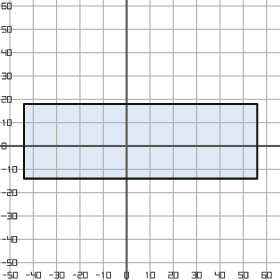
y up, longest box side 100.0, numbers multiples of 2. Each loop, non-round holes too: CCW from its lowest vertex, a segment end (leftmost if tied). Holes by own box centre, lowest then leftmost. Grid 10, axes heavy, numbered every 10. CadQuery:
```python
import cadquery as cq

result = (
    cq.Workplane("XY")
    .moveTo(-44.0, -14.0)
    .lineTo(56.0, -14.0)
    .lineTo(56.0, 18.0)
    .lineTo(-44.0, 18.0)
    .close()
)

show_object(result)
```